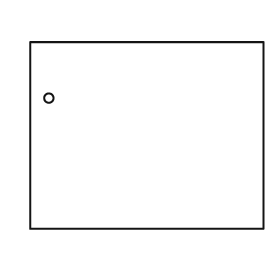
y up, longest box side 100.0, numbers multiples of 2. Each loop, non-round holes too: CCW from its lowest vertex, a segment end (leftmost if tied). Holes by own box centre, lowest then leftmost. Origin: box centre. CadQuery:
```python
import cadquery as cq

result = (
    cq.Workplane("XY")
    .moveTo(-50.0, -40.0)
    .lineTo(50.0, -40.0)
    .lineTo(50.0, 40.0)
    .lineTo(-50.0, 40.0)
    .close()
    .moveTo(-42.0, 16.0)
    .circle(2.0)
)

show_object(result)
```